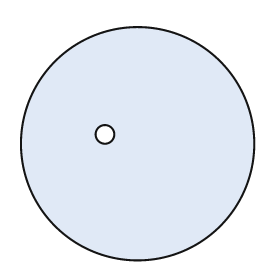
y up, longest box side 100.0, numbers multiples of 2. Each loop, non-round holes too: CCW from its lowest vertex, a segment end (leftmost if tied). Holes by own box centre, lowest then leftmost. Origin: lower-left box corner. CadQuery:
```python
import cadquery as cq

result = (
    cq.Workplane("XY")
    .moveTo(50.0, 50.0)
    .circle(50.0)
    .moveTo(36.0, 54.0)
    .circle(4.0)
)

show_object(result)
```